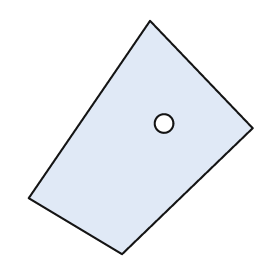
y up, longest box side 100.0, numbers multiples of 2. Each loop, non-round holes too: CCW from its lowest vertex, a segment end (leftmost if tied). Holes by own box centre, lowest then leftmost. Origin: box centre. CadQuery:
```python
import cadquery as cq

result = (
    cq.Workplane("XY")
    .moveTo(-8.0, -50.0)
    .lineTo(48.0, 4.0)
    .lineTo(4.0, 50.0)
    .lineTo(-48.0, -26.0)
    .close()
    .moveTo(10.0, 6.0)
    .circle(4.0)
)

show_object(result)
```